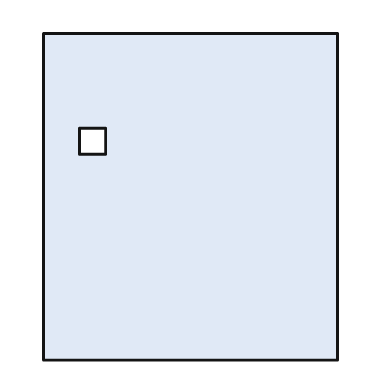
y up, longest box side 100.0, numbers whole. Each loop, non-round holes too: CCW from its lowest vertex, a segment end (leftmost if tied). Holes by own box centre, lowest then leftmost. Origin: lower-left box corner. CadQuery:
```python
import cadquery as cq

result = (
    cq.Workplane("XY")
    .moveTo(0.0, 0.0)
    .lineTo(90.0, 0.0)
    .lineTo(90.0, 100.0)
    .lineTo(0.0, 100.0)
    .close()
    .moveTo(11.0, 63.0)
    .lineTo(19.0, 63.0)
    .lineTo(19.0, 71.0)
    .lineTo(11.0, 71.0)
    .close()
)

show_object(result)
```